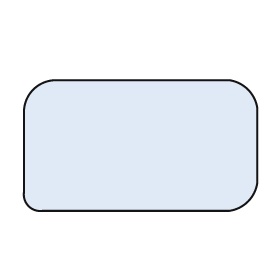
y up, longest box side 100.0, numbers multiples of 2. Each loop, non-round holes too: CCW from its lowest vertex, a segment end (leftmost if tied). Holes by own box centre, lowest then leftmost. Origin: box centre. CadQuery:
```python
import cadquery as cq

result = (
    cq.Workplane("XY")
    .moveTo(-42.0, -28.0)
    .lineTo(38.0, -28.0)
    .threePointArc((46.0, -24.0), (50.0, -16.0))
    .lineTo(50.0, 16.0)
    .threePointArc((46.0, 24.0), (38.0, 28.0))
    .lineTo(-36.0, 28.0)
    .threePointArc((-46.0, 24.0), (-50.0, 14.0))
    .lineTo(-50.0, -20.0)
    .threePointArc((-48.0, -26.0), (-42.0, -28.0))
    .close()
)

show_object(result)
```